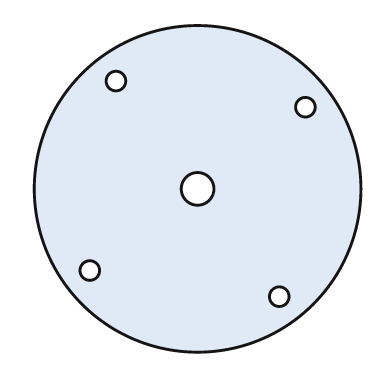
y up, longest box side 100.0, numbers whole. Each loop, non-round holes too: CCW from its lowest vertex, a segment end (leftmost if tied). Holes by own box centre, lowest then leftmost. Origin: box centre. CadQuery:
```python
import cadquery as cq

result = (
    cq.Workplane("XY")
    .moveTo(0.0, 0.0)
    .circle(50.0)
    .moveTo(25.0, -33.0)
    .circle(3.0)
    .moveTo(-33.0, -25.0)
    .circle(3.0)
    .moveTo(0.0, 0.0)
    .circle(5.0)
    .moveTo(33.0, 25.0)
    .circle(3.0)
    .moveTo(-25.0, 33.0)
    .circle(3.0)
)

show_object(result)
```